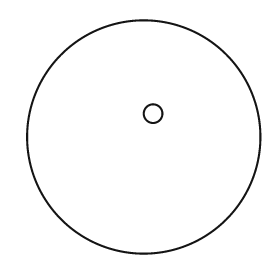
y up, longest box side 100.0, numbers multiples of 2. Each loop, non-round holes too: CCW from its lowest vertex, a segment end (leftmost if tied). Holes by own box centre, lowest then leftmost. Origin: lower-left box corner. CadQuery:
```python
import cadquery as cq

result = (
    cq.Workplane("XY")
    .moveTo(50.0, 50.0)
    .circle(50.0)
    .moveTo(54.0, 60.0)
    .circle(4.0)
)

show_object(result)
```